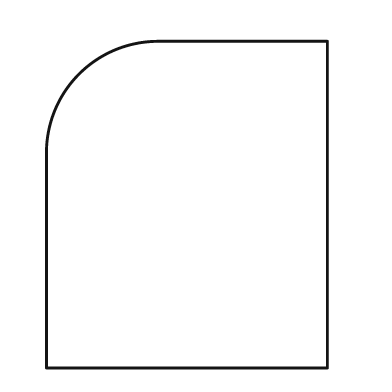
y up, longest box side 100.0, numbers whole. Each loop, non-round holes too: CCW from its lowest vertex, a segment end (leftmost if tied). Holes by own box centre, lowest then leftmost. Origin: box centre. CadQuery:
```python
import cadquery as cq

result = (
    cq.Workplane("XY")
    .moveTo(-43.0, -50.0)
    .lineTo(43.0, -50.0)
    .lineTo(43.0, 50.0)
    .lineTo(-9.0, 50.0)
    .threePointArc((-33.0, 40.0), (-43.0, 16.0))
    .close()
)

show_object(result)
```